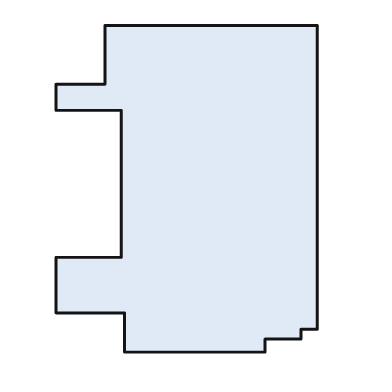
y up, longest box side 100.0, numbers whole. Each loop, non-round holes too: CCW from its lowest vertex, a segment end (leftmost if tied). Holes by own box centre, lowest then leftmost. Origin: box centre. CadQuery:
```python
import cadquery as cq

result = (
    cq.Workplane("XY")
    .moveTo(-19.0, -50.0)
    .lineTo(24.0, -50.0)
    .lineTo(24.0, -46.0)
    .lineTo(35.0, -46.0)
    .lineTo(35.0, -43.0)
    .lineTo(40.0, -43.0)
    .lineTo(40.0, 50.0)
    .lineTo(-25.0, 50.0)
    .lineTo(-25.0, 32.0)
    .lineTo(-40.0, 32.0)
    .lineTo(-40.0, 24.0)
    .lineTo(-20.0, 24.0)
    .lineTo(-20.0, -21.0)
    .lineTo(-40.0, -21.0)
    .lineTo(-40.0, -38.0)
    .lineTo(-19.0, -38.0)
    .close()
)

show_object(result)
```